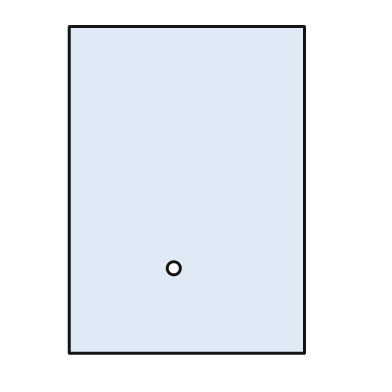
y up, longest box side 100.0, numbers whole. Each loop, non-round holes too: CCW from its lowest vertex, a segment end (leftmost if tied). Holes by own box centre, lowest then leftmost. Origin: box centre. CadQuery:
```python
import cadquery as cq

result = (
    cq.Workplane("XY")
    .moveTo(-36.0, -50.0)
    .lineTo(36.0, -50.0)
    .lineTo(36.0, 50.0)
    .lineTo(-36.0, 50.0)
    .close()
    .moveTo(-4.0, -24.0)
    .circle(2.0)
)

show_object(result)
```